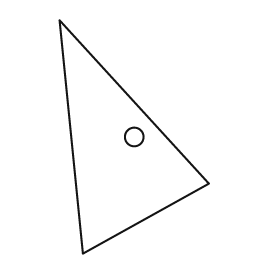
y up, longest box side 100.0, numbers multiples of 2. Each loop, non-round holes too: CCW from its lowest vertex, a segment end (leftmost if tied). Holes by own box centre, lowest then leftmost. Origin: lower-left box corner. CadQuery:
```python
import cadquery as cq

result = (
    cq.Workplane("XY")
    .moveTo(10.0, 0.0)
    .lineTo(64.0, 30.0)
    .lineTo(0.0, 100.0)
    .close()
    .moveTo(32.0, 50.0)
    .circle(4.0)
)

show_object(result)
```